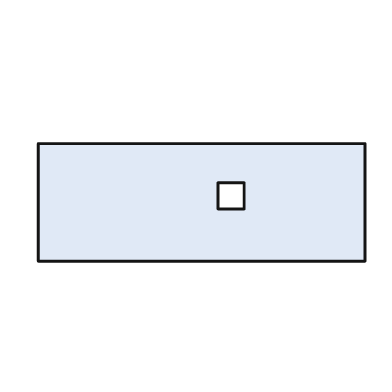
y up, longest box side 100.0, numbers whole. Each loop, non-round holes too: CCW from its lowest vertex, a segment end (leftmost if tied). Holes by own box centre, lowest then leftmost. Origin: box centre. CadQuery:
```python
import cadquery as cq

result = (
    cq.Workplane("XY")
    .moveTo(-50.0, -18.0)
    .lineTo(50.0, -18.0)
    .lineTo(50.0, 18.0)
    .lineTo(-50.0, 18.0)
    .close()
    .moveTo(5.0, -2.0)
    .lineTo(13.0, -2.0)
    .lineTo(13.0, 6.0)
    .lineTo(5.0, 6.0)
    .close()
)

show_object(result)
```